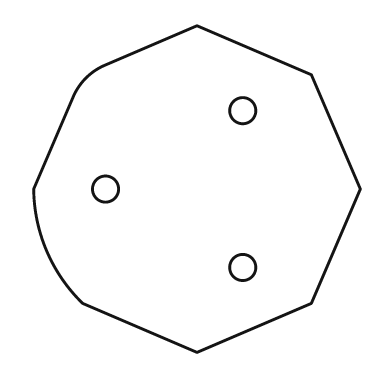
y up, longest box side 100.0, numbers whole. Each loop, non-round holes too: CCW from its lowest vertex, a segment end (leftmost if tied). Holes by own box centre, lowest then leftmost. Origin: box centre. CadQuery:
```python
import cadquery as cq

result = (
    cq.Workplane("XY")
    .moveTo(0.0, -50.0)
    .lineTo(35.0, -35.0)
    .lineTo(50.0, 0.0)
    .lineTo(35.0, 35.0)
    .lineTo(0.0, 50.0)
    .lineTo(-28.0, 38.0)
    .threePointArc((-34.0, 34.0), (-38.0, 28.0))
    .lineTo(-50.0, 0.0)
    .threePointArc((-46.0, -19.0), (-35.0, -35.0))
    .close()
    .moveTo(14.0, -24.0)
    .circle(4.0)
    .moveTo(-28.0, 0.0)
    .circle(4.0)
    .moveTo(14.0, 24.0)
    .circle(4.0)
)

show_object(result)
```